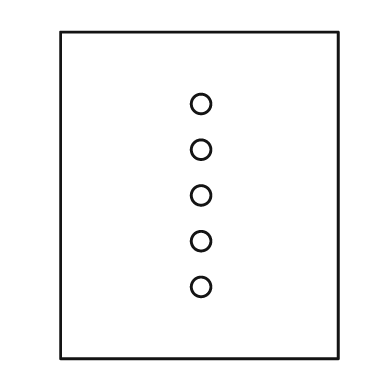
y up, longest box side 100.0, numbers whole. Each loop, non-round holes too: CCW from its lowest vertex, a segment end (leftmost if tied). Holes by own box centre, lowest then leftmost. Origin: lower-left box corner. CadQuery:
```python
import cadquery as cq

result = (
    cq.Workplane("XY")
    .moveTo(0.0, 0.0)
    .lineTo(85.0, 0.0)
    .lineTo(85.0, 100.0)
    .lineTo(0.0, 100.0)
    .close()
    .moveTo(43.0, 22.0)
    .circle(3.0)
    .moveTo(43.0, 36.0)
    .circle(3.0)
    .moveTo(43.0, 50.0)
    .circle(3.0)
    .moveTo(43.0, 64.0)
    .circle(3.0)
    .moveTo(43.0, 78.0)
    .circle(3.0)
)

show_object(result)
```